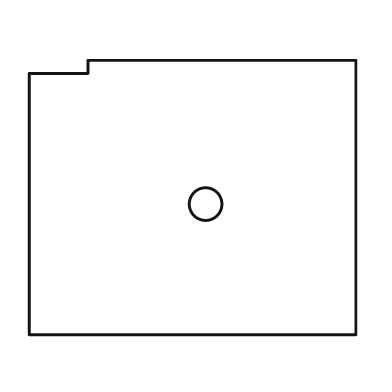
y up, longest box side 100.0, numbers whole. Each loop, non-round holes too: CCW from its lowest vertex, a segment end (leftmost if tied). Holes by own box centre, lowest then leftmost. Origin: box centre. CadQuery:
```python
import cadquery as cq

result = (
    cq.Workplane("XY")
    .moveTo(-50.0, -42.0)
    .lineTo(50.0, -42.0)
    .lineTo(50.0, 42.0)
    .lineTo(-32.0, 42.0)
    .lineTo(-32.0, 38.0)
    .lineTo(-50.0, 38.0)
    .close()
    .moveTo(4.0, -2.0)
    .circle(5.0)
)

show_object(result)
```